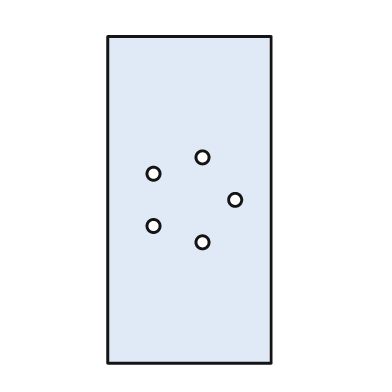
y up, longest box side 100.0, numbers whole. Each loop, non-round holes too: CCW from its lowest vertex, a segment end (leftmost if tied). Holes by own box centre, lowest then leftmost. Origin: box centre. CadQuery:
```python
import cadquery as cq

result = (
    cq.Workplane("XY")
    .moveTo(-25.0, -50.0)
    .lineTo(25.0, -50.0)
    .lineTo(25.0, 50.0)
    .lineTo(-25.0, 50.0)
    .close()
    .moveTo(4.0, -13.0)
    .circle(2.0)
    .moveTo(-11.0, -8.0)
    .circle(2.0)
    .moveTo(14.0, 0.0)
    .circle(2.0)
    .moveTo(-11.0, 8.0)
    .circle(2.0)
    .moveTo(4.0, 13.0)
    .circle(2.0)
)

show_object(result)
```